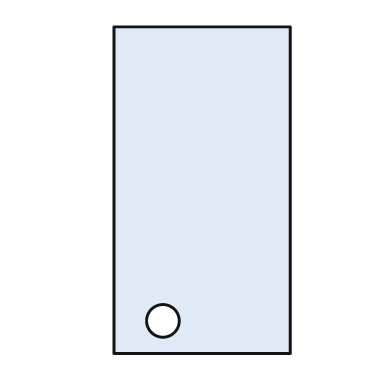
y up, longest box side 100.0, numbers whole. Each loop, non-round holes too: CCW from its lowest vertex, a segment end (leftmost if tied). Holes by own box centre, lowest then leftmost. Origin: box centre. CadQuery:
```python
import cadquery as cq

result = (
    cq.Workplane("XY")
    .moveTo(-27.0, -50.0)
    .lineTo(27.0, -50.0)
    .lineTo(27.0, 50.0)
    .lineTo(-27.0, 50.0)
    .close()
    .moveTo(-12.0, -40.0)
    .circle(5.0)
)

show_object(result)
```